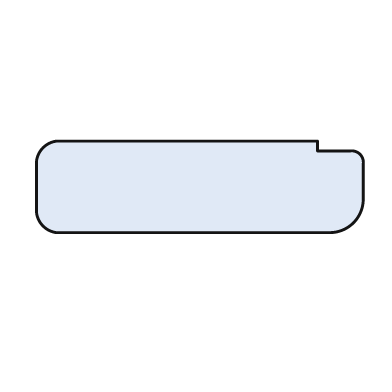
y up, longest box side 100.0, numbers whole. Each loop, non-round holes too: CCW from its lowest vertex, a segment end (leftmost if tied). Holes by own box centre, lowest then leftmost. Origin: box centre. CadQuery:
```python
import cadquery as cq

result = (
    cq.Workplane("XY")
    .moveTo(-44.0, -14.0)
    .lineTo(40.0, -14.0)
    .threePointArc((47.0, -11.0), (50.0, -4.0))
    .lineTo(50.0, 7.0)
    .threePointArc((49.0, 10.0), (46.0, 11.0))
    .lineTo(36.0, 11.0)
    .lineTo(36.0, 14.0)
    .lineTo(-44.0, 14.0)
    .threePointArc((-48.0, 12.0), (-50.0, 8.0))
    .lineTo(-50.0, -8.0)
    .threePointArc((-48.0, -12.0), (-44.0, -14.0))
    .close()
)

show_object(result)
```